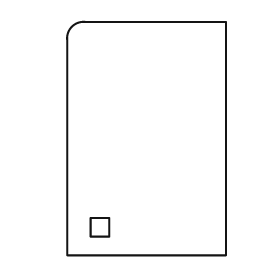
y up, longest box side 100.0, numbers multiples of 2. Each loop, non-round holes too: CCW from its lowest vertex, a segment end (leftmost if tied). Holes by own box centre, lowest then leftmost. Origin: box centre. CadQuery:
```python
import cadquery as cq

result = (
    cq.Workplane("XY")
    .moveTo(-34.0, -50.0)
    .lineTo(34.0, -50.0)
    .lineTo(34.0, 50.0)
    .lineTo(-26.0, 50.0)
    .threePointArc((-32.0, 48.0), (-34.0, 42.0))
    .close()
    .moveTo(-24.0, -42.0)
    .lineTo(-16.0, -42.0)
    .lineTo(-16.0, -34.0)
    .lineTo(-24.0, -34.0)
    .close()
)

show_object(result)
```